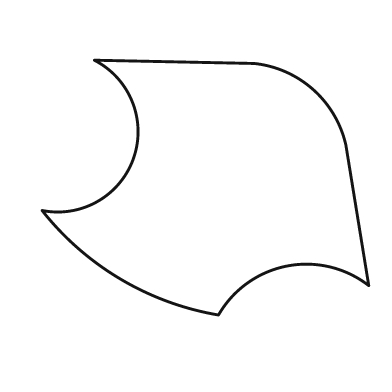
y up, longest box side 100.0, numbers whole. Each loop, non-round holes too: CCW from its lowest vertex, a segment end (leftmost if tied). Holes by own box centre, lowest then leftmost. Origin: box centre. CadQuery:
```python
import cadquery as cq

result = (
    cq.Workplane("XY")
    .moveTo(4.0, -39.0)
    .threePointArc((25.0, -24.0), (50.0, -30.0))
    .lineTo(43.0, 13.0)
    .threePointArc((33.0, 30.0), (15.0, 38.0))
    .lineTo(-34.0, 39.0)
    .threePointArc((-22.0, 9.0), (-50.0, -7.0))
    .threePointArc((-26.0, -28.0), (4.0, -39.0))
    .close()
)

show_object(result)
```